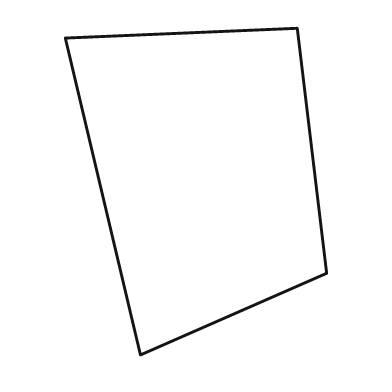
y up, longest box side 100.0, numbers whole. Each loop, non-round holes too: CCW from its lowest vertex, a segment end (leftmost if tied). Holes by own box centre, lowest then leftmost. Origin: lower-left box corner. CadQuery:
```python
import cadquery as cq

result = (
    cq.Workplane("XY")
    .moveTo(23.0, 0.0)
    .lineTo(80.0, 25.0)
    .lineTo(71.0, 100.0)
    .lineTo(0.0, 97.0)
    .close()
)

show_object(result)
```